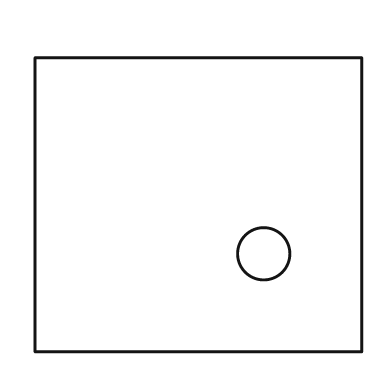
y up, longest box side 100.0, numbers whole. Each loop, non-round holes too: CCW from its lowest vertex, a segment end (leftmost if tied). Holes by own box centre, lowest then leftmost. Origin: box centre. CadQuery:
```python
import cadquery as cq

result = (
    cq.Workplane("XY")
    .moveTo(-50.0, -45.0)
    .lineTo(50.0, -45.0)
    .lineTo(50.0, 45.0)
    .lineTo(-50.0, 45.0)
    .close()
    .moveTo(20.0, -15.0)
    .circle(8.0)
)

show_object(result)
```